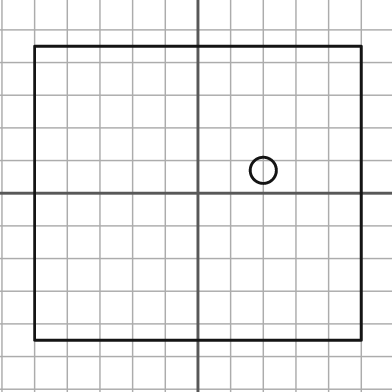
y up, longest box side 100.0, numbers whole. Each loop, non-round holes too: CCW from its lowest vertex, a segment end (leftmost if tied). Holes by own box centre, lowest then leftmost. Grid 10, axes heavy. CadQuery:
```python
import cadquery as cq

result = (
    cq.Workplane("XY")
    .moveTo(-50.0, -45.0)
    .lineTo(50.0, -45.0)
    .lineTo(50.0, 45.0)
    .lineTo(-50.0, 45.0)
    .close()
    .moveTo(20.0, 7.0)
    .circle(4.0)
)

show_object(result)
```